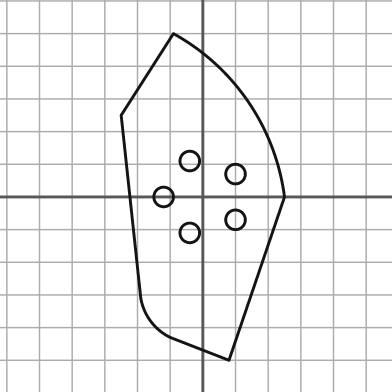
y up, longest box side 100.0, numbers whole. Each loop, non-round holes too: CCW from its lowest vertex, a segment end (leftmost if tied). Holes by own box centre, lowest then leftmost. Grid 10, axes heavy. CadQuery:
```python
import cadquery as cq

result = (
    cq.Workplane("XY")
    .moveTo(8.0, -50.0)
    .lineTo(25.0, 0.0)
    .threePointArc((14.0, 29.0), (-9.0, 50.0))
    .lineTo(-25.0, 25.0)
    .lineTo(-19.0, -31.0)
    .threePointArc((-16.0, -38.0), (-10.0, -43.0))
    .close()
    .moveTo(-4.0, -11.0)
    .circle(3.0)
    .moveTo(10.0, -7.0)
    .circle(3.0)
    .moveTo(-12.0, 0.0)
    .circle(3.0)
    .moveTo(10.0, 7.0)
    .circle(3.0)
    .moveTo(-4.0, 11.0)
    .circle(3.0)
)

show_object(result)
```